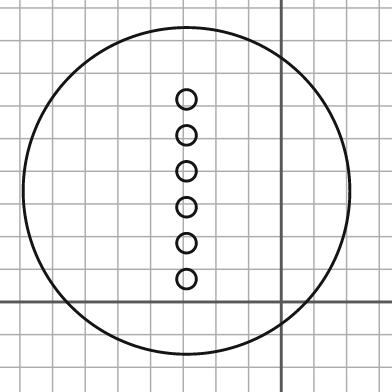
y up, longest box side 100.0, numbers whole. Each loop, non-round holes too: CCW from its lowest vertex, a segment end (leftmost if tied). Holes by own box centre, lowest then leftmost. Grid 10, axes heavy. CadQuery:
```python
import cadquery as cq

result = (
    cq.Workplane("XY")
    .moveTo(-29.0, 34.0)
    .circle(50.0)
    .moveTo(-29.0, 7.0)
    .circle(3.0)
    .moveTo(-29.0, 18.0)
    .circle(3.0)
    .moveTo(-29.0, 29.0)
    .circle(3.0)
    .moveTo(-29.0, 40.0)
    .circle(3.0)
    .moveTo(-29.0, 51.0)
    .circle(3.0)
    .moveTo(-29.0, 62.0)
    .circle(3.0)
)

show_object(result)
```